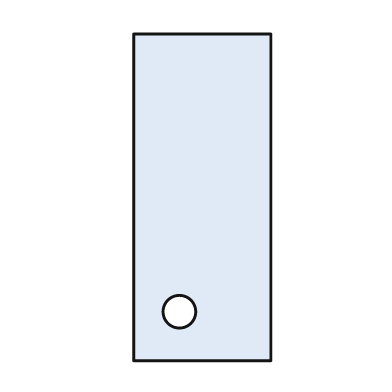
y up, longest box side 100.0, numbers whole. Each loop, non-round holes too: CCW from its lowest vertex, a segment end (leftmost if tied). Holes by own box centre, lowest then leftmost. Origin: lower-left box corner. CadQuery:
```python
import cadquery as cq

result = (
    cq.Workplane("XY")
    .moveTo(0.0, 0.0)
    .lineTo(42.0, 0.0)
    .lineTo(42.0, 100.0)
    .lineTo(0.0, 100.0)
    .close()
    .moveTo(14.0, 15.0)
    .circle(5.0)
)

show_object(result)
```